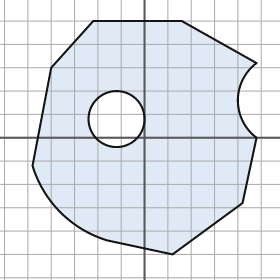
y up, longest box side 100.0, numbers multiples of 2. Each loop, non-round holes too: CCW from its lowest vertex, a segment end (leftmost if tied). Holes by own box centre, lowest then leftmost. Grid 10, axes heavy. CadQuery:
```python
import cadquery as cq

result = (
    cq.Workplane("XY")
    .moveTo(12.0, -50.0)
    .lineTo(42.0, -28.0)
    .lineTo(48.0, 0.0)
    .threePointArc((40.0, 16.0), (48.0, 32.0))
    .lineTo(16.0, 50.0)
    .lineTo(-22.0, 50.0)
    .lineTo(-40.0, 30.0)
    .lineTo(-48.0, -12.0)
    .threePointArc((-36.0, -32.0), (-16.0, -44.0))
    .close()
    .moveTo(-12.0, 8.0)
    .circle(12.0)
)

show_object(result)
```